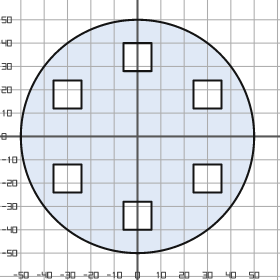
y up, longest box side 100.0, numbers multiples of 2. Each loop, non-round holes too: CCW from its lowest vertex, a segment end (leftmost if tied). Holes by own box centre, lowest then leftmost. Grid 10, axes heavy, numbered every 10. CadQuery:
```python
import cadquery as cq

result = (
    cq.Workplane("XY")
    .moveTo(0.0, 0.0)
    .circle(50.0)
    .moveTo(-6.0, -40.0)
    .lineTo(6.0, -40.0)
    .lineTo(6.0, -28.0)
    .lineTo(-6.0, -28.0)
    .close()
    .moveTo(-36.0, -24.0)
    .lineTo(-24.0, -24.0)
    .lineTo(-24.0, -12.0)
    .lineTo(-36.0, -12.0)
    .close()
    .moveTo(24.0, -24.0)
    .lineTo(36.0, -24.0)
    .lineTo(36.0, -12.0)
    .lineTo(24.0, -12.0)
    .close()
    .moveTo(-36.0, 12.0)
    .lineTo(-24.0, 12.0)
    .lineTo(-24.0, 24.0)
    .lineTo(-36.0, 24.0)
    .close()
    .moveTo(24.0, 12.0)
    .lineTo(36.0, 12.0)
    .lineTo(36.0, 24.0)
    .lineTo(24.0, 24.0)
    .close()
    .moveTo(-6.0, 28.0)
    .lineTo(6.0, 28.0)
    .lineTo(6.0, 40.0)
    .lineTo(-6.0, 40.0)
    .close()
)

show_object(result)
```